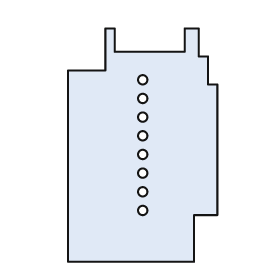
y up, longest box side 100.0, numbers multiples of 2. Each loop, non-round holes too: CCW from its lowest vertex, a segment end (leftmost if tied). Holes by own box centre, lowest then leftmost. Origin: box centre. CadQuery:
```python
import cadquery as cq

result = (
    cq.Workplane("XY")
    .moveTo(-32.0, -50.0)
    .lineTo(22.0, -50.0)
    .lineTo(22.0, -30.0)
    .lineTo(32.0, -30.0)
    .lineTo(32.0, 26.0)
    .lineTo(28.0, 26.0)
    .lineTo(28.0, 38.0)
    .lineTo(24.0, 38.0)
    .lineTo(24.0, 50.0)
    .lineTo(18.0, 50.0)
    .lineTo(18.0, 40.0)
    .lineTo(-12.0, 40.0)
    .lineTo(-12.0, 50.0)
    .lineTo(-16.0, 50.0)
    .lineTo(-16.0, 32.0)
    .lineTo(-32.0, 32.0)
    .close()
    .moveTo(0.0, -28.0)
    .circle(2.0)
    .moveTo(0.0, -20.0)
    .circle(2.0)
    .moveTo(0.0, -12.0)
    .circle(2.0)
    .moveTo(0.0, -4.0)
    .circle(2.0)
    .moveTo(0.0, 4.0)
    .circle(2.0)
    .moveTo(0.0, 12.0)
    .circle(2.0)
    .moveTo(0.0, 20.0)
    .circle(2.0)
    .moveTo(0.0, 28.0)
    .circle(2.0)
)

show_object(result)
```